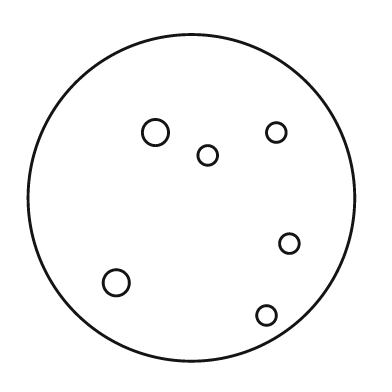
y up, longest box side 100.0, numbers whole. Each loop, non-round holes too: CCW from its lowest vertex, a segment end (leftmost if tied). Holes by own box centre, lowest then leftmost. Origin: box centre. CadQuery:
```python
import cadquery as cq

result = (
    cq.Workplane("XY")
    .moveTo(0.0, 0.0)
    .circle(50.0)
    .moveTo(23.0, -36.0)
    .circle(3.0)
    .moveTo(-23.0, -26.0)
    .circle(4.0)
    .moveTo(30.0, -14.0)
    .circle(3.0)
    .moveTo(5.0, 13.0)
    .circle(3.0)
    .moveTo(-11.0, 20.0)
    .circle(4.0)
    .moveTo(26.0, 20.0)
    .circle(3.0)
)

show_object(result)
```